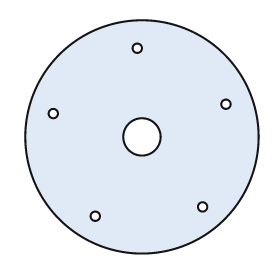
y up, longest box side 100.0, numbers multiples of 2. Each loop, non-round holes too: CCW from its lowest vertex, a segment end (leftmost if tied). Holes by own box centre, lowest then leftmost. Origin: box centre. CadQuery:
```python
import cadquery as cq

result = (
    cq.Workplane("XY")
    .moveTo(0.0, 0.0)
    .circle(50.0)
    .moveTo(-20.0, -34.0)
    .circle(2.0)
    .moveTo(26.0, -30.0)
    .circle(2.0)
    .moveTo(0.0, 0.0)
    .circle(8.0)
    .moveTo(-38.0, 10.0)
    .circle(2.0)
    .moveTo(36.0, 14.0)
    .circle(2.0)
    .moveTo(-2.0, 38.0)
    .circle(2.0)
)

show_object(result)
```